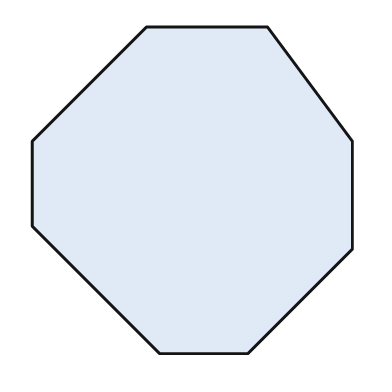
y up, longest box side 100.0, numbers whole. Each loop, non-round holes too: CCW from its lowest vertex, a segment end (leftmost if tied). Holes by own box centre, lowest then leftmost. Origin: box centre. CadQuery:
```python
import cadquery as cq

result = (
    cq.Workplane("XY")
    .moveTo(-10.0, -50.0)
    .lineTo(17.0, -50.0)
    .lineTo(49.0, -18.0)
    .lineTo(49.0, 15.0)
    .lineTo(23.0, 50.0)
    .lineTo(-14.0, 50.0)
    .lineTo(-49.0, 15.0)
    .lineTo(-49.0, -11.0)
    .close()
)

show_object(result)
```